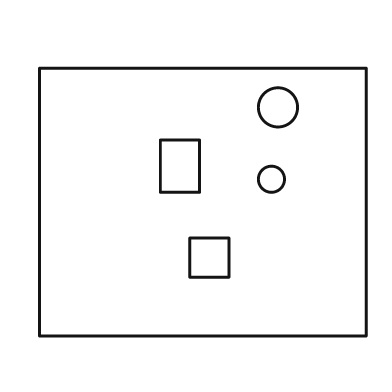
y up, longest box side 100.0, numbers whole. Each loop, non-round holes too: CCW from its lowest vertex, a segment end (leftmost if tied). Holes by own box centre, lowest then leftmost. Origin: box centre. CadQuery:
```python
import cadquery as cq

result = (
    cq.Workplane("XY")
    .moveTo(-50.0, -41.0)
    .lineTo(50.0, -41.0)
    .lineTo(50.0, 41.0)
    .lineTo(-50.0, 41.0)
    .close()
    .moveTo(-4.0, -23.0)
    .lineTo(8.0, -23.0)
    .lineTo(8.0, -11.0)
    .lineTo(-4.0, -11.0)
    .close()
    .moveTo(21.0, 7.0)
    .circle(4.0)
    .moveTo(-13.0, 3.0)
    .lineTo(-1.0, 3.0)
    .lineTo(-1.0, 19.0)
    .lineTo(-13.0, 19.0)
    .close()
    .moveTo(23.0, 29.0)
    .circle(6.0)
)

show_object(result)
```